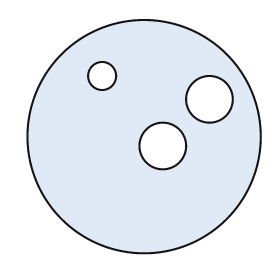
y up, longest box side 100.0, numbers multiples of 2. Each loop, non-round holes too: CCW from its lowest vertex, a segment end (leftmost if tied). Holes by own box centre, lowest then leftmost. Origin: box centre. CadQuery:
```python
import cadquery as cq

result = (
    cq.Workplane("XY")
    .moveTo(0.0, 0.0)
    .circle(50.0)
    .moveTo(8.0, -4.0)
    .circle(10.0)
    .moveTo(28.0, 16.0)
    .circle(10.0)
    .moveTo(-18.0, 26.0)
    .circle(6.0)
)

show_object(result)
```